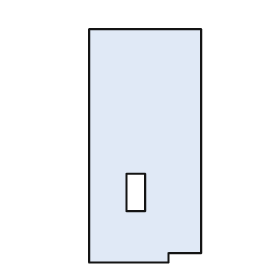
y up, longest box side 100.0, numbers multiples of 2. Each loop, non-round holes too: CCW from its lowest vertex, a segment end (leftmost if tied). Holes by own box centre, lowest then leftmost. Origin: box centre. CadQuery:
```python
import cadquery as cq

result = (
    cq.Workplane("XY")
    .moveTo(-24.0, -50.0)
    .lineTo(10.0, -50.0)
    .lineTo(10.0, -46.0)
    .lineTo(24.0, -46.0)
    .lineTo(24.0, 50.0)
    .lineTo(-24.0, 50.0)
    .close()
    .moveTo(-8.0, -28.0)
    .lineTo(0.0, -28.0)
    .lineTo(0.0, -12.0)
    .lineTo(-8.0, -12.0)
    .close()
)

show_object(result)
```